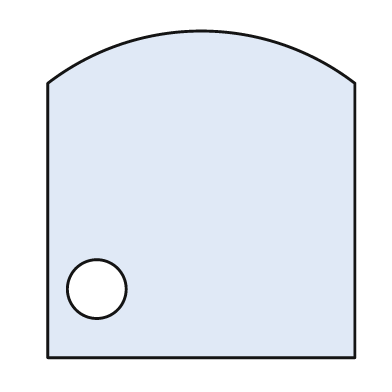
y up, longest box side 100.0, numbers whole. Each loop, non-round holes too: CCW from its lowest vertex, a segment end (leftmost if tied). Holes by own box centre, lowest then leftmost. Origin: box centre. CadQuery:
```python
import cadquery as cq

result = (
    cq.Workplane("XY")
    .moveTo(-47.0, -50.0)
    .lineTo(47.0, -50.0)
    .lineTo(47.0, 34.0)
    .threePointArc((0.0, 50.0), (-47.0, 34.0))
    .close()
    .moveTo(-32.0, -29.0)
    .circle(9.0)
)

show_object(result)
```